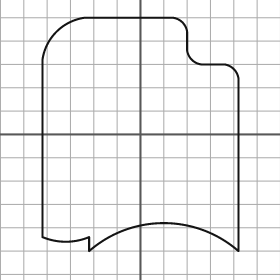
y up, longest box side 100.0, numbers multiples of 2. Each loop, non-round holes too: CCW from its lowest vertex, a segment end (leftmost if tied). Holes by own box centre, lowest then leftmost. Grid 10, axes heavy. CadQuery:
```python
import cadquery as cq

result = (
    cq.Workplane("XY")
    .moveTo(-22.0, -50.0)
    .threePointArc((10.0, -38.0), (42.0, -50.0))
    .lineTo(42.0, 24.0)
    .threePointArc((40.0, 28.0), (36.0, 30.0))
    .lineTo(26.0, 30.0)
    .threePointArc((22.0, 32.0), (20.0, 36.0))
    .lineTo(20.0, 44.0)
    .threePointArc((18.0, 48.0), (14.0, 50.0))
    .lineTo(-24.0, 50.0)
    .threePointArc((-36.0, 44.0), (-42.0, 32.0))
    .lineTo(-42.0, -44.0)
    .threePointArc((-32.0, -46.0), (-22.0, -44.0))
    .close()
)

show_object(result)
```